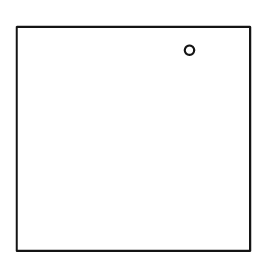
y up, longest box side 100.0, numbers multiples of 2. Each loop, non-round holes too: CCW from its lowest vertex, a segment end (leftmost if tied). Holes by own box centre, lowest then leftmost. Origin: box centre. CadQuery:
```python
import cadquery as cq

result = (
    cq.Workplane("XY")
    .moveTo(-50.0, -48.0)
    .lineTo(50.0, -48.0)
    .lineTo(50.0, 48.0)
    .lineTo(-50.0, 48.0)
    .close()
    .moveTo(24.0, 38.0)
    .circle(2.0)
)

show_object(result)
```